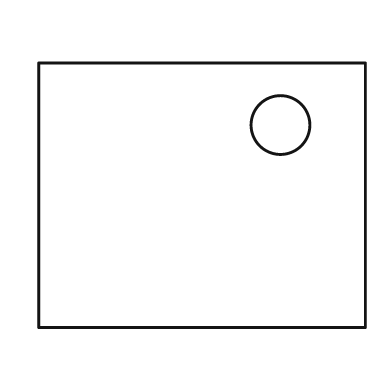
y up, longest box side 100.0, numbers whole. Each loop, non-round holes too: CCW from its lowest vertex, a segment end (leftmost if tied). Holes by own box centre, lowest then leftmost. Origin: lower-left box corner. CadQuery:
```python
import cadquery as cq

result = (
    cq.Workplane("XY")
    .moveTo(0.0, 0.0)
    .lineTo(100.0, 0.0)
    .lineTo(100.0, 81.0)
    .lineTo(0.0, 81.0)
    .close()
    .moveTo(74.0, 62.0)
    .circle(9.0)
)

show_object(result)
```